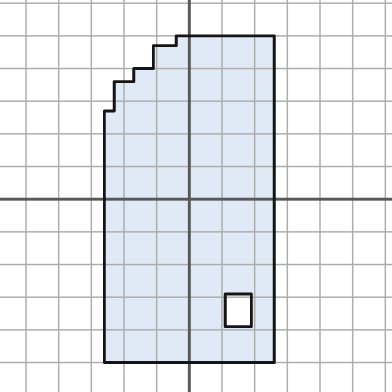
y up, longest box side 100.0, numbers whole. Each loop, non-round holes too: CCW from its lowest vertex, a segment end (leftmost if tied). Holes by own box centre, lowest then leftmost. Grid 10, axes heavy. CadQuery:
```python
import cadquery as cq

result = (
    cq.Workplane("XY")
    .moveTo(-26.0, -50.0)
    .lineTo(26.0, -50.0)
    .lineTo(26.0, 50.0)
    .lineTo(-4.0, 50.0)
    .lineTo(-4.0, 47.0)
    .lineTo(-11.0, 47.0)
    .lineTo(-11.0, 40.0)
    .lineTo(-17.0, 40.0)
    .lineTo(-17.0, 36.0)
    .lineTo(-23.0, 36.0)
    .lineTo(-23.0, 27.0)
    .lineTo(-26.0, 27.0)
    .close()
    .moveTo(11.0, -39.0)
    .lineTo(19.0, -39.0)
    .lineTo(19.0, -29.0)
    .lineTo(11.0, -29.0)
    .close()
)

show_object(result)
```